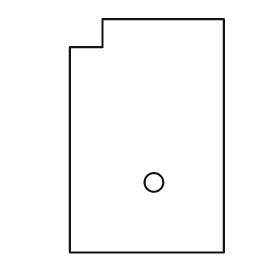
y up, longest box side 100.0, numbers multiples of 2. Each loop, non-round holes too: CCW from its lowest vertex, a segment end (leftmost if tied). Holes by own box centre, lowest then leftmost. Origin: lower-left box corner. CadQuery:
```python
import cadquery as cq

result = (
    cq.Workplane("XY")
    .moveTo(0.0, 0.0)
    .lineTo(66.0, 0.0)
    .lineTo(66.0, 100.0)
    .lineTo(14.0, 100.0)
    .lineTo(14.0, 88.0)
    .lineTo(0.0, 88.0)
    .close()
    .moveTo(36.0, 30.0)
    .circle(4.0)
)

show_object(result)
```